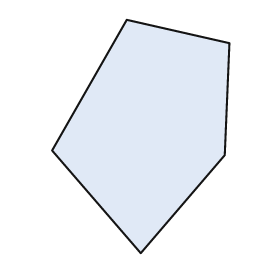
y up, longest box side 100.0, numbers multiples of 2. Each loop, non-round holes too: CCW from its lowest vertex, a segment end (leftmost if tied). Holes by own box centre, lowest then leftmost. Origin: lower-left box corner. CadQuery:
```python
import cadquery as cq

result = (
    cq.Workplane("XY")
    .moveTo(38.0, 0.0)
    .lineTo(74.0, 42.0)
    .lineTo(76.0, 90.0)
    .lineTo(32.0, 100.0)
    .lineTo(0.0, 44.0)
    .close()
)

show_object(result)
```